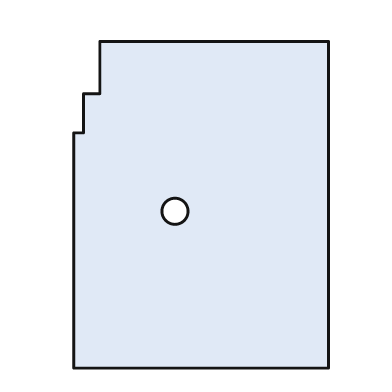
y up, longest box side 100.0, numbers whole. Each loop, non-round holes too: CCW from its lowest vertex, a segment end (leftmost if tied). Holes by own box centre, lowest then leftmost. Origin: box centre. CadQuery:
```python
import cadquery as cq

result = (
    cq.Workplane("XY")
    .moveTo(-39.0, -50.0)
    .lineTo(39.0, -50.0)
    .lineTo(39.0, 50.0)
    .lineTo(-31.0, 50.0)
    .lineTo(-31.0, 34.0)
    .lineTo(-36.0, 34.0)
    .lineTo(-36.0, 22.0)
    .lineTo(-39.0, 22.0)
    .close()
    .moveTo(-8.0, -2.0)
    .circle(4.0)
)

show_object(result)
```